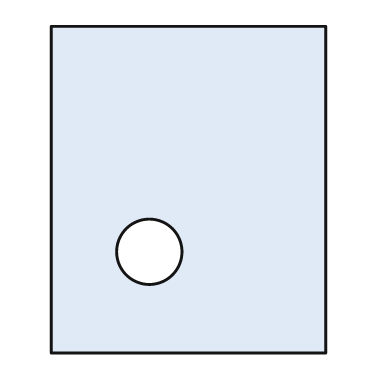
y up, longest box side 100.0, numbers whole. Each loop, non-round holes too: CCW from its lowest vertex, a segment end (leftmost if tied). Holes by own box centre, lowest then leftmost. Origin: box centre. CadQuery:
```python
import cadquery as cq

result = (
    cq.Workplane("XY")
    .moveTo(-42.0, -50.0)
    .lineTo(42.0, -50.0)
    .lineTo(42.0, 50.0)
    .lineTo(-42.0, 50.0)
    .close()
    .moveTo(-12.0, -19.0)
    .circle(10.0)
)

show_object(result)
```